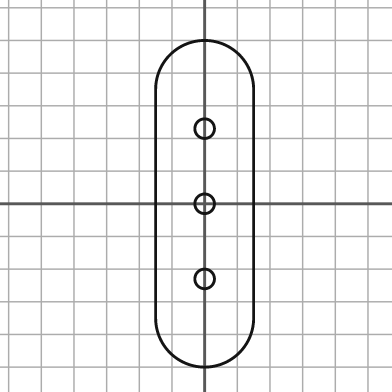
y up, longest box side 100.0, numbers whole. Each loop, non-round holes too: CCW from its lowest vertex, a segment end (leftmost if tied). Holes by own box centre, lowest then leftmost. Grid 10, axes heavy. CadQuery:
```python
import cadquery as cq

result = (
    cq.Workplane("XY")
    .moveTo(-15.0, -35.0)
    .threePointArc((0.0, -50.0), (15.0, -35.0))
    .lineTo(15.0, 35.0)
    .threePointArc((0.0, 50.0), (-15.0, 35.0))
    .close()
    .moveTo(0.0, -23.0)
    .circle(3.0)
    .moveTo(0.0, 0.0)
    .circle(3.0)
    .moveTo(0.0, 23.0)
    .circle(3.0)
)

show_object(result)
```